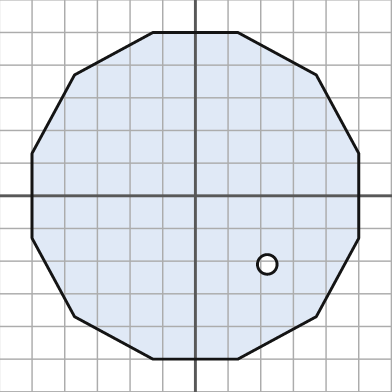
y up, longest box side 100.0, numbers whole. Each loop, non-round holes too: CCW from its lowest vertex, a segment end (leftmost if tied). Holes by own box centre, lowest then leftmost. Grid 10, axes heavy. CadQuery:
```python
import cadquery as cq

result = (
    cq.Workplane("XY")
    .moveTo(-13.0, -50.0)
    .lineTo(13.0, -50.0)
    .lineTo(37.0, -37.0)
    .lineTo(50.0, -13.0)
    .lineTo(50.0, 13.0)
    .lineTo(37.0, 37.0)
    .lineTo(13.0, 50.0)
    .lineTo(-13.0, 50.0)
    .lineTo(-37.0, 37.0)
    .lineTo(-50.0, 13.0)
    .lineTo(-50.0, -13.0)
    .lineTo(-37.0, -37.0)
    .close()
    .moveTo(22.0, -21.0)
    .circle(3.0)
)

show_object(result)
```